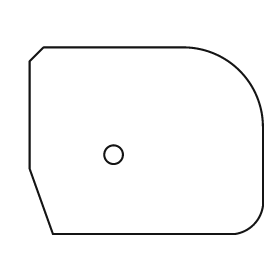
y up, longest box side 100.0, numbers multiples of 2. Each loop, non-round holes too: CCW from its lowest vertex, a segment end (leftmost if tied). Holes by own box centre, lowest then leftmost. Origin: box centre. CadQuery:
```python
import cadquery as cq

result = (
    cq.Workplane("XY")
    .moveTo(-40.0, -40.0)
    .lineTo(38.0, -40.0)
    .threePointArc((46.0, -36.0), (50.0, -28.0))
    .lineTo(50.0, 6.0)
    .threePointArc((40.0, 30.0), (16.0, 40.0))
    .lineTo(-44.0, 40.0)
    .lineTo(-50.0, 34.0)
    .lineTo(-50.0, -12.0)
    .close()
    .moveTo(-14.0, -6.0)
    .circle(4.0)
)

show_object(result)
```